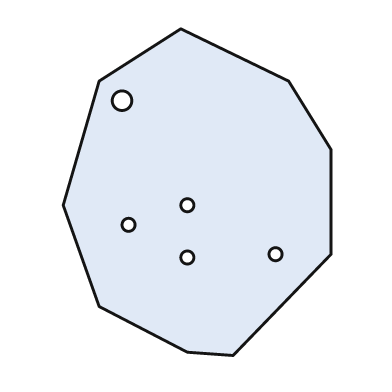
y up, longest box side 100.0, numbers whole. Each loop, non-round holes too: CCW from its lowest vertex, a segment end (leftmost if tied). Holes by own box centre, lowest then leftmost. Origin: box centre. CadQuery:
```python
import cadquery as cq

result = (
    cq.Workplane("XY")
    .moveTo(11.0, -50.0)
    .lineTo(41.0, -19.0)
    .lineTo(41.0, 13.0)
    .lineTo(28.0, 34.0)
    .lineTo(-5.0, 50.0)
    .lineTo(-30.0, 34.0)
    .lineTo(-41.0, -4.0)
    .lineTo(-30.0, -35.0)
    .lineTo(-3.0, -49.0)
    .close()
    .moveTo(-3.0, -20.0)
    .circle(2.0)
    .moveTo(24.0, -19.0)
    .circle(2.0)
    .moveTo(-21.0, -10.0)
    .circle(2.0)
    .moveTo(-3.0, -4.0)
    .circle(2.0)
    .moveTo(-23.0, 28.0)
    .circle(3.0)
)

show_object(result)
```